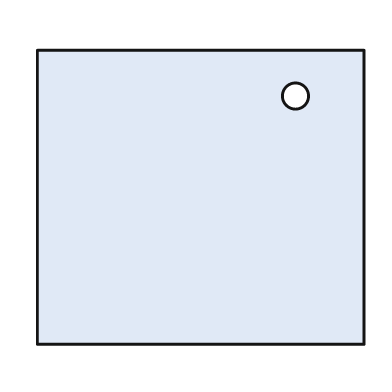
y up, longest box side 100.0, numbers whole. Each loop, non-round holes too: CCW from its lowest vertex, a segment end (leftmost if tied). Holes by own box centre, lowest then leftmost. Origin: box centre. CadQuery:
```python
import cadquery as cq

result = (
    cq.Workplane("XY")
    .moveTo(-50.0, -45.0)
    .lineTo(50.0, -45.0)
    .lineTo(50.0, 45.0)
    .lineTo(-50.0, 45.0)
    .close()
    .moveTo(29.0, 31.0)
    .circle(4.0)
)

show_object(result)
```